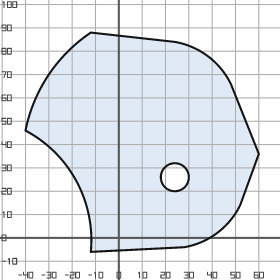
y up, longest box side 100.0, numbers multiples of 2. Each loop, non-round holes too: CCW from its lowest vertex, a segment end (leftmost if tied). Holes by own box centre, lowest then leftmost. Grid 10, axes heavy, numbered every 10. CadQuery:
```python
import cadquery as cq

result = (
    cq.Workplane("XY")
    .moveTo(-12.0, -6.0)
    .lineTo(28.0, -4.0)
    .threePointArc((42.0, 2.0), (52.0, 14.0))
    .lineTo(60.0, 36.0)
    .lineTo(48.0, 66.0)
    .threePointArc((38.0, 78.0), (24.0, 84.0))
    .lineTo(-12.0, 88.0)
    .threePointArc((-30.0, 70.0), (-40.0, 46.0))
    .threePointArc((-18.0, 24.0), (-12.0, -6.0))
    .close()
    .moveTo(24.0, 26.0)
    .circle(6.0)
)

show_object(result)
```